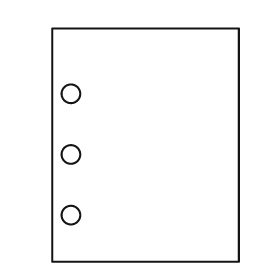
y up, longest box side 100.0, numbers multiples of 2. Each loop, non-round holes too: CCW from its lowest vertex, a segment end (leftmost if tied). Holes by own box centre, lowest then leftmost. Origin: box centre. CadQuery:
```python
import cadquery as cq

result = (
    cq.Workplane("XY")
    .moveTo(-40.0, -50.0)
    .lineTo(40.0, -50.0)
    .lineTo(40.0, 50.0)
    .lineTo(-40.0, 50.0)
    .close()
    .moveTo(-32.0, -30.0)
    .circle(4.0)
    .moveTo(-32.0, -4.0)
    .circle(4.0)
    .moveTo(-32.0, 22.0)
    .circle(4.0)
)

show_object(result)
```